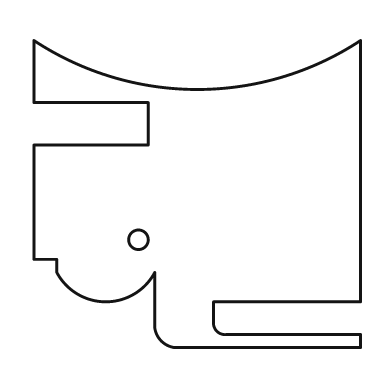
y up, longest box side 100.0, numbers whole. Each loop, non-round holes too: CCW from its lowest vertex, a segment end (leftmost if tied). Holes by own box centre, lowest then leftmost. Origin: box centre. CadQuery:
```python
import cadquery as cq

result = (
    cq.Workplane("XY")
    .moveTo(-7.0, -47.0)
    .lineTo(50.0, -47.0)
    .lineTo(50.0, -43.0)
    .lineTo(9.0, -43.0)
    .threePointArc((6.0, -42.0), (5.0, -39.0))
    .lineTo(5.0, -33.0)
    .lineTo(50.0, -33.0)
    .lineTo(50.0, 47.0)
    .threePointArc((0.0, 32.0), (-50.0, 47.0))
    .lineTo(-50.0, 28.0)
    .lineTo(-15.0, 28.0)
    .lineTo(-15.0, 15.0)
    .lineTo(-50.0, 15.0)
    .lineTo(-50.0, -20.0)
    .lineTo(-43.0, -20.0)
    .lineTo(-43.0, -24.0)
    .threePointArc((-28.0, -33.0), (-13.0, -24.0))
    .lineTo(-13.0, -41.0)
    .threePointArc((-11.0, -45.0), (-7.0, -47.0))
    .close()
    .moveTo(-18.0, -14.0)
    .circle(3.0)
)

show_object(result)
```